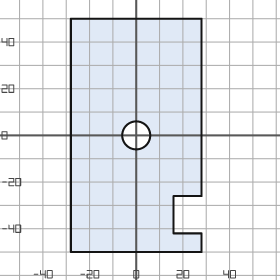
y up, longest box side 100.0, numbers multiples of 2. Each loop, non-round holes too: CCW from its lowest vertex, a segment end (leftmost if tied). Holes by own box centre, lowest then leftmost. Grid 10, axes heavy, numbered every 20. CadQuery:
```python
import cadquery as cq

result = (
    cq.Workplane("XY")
    .moveTo(-28.0, -50.0)
    .lineTo(28.0, -50.0)
    .lineTo(28.0, -42.0)
    .lineTo(16.0, -42.0)
    .lineTo(16.0, -26.0)
    .lineTo(28.0, -26.0)
    .lineTo(28.0, 50.0)
    .lineTo(-28.0, 50.0)
    .close()
    .moveTo(0.0, 0.0)
    .circle(6.0)
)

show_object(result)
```